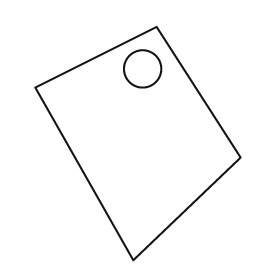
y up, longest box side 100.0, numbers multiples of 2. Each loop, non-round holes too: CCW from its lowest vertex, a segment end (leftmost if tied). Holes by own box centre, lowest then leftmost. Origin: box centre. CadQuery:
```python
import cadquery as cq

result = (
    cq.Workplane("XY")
    .moveTo(-2.0, -50.0)
    .lineTo(44.0, -6.0)
    .lineTo(8.0, 50.0)
    .lineTo(-44.0, 24.0)
    .close()
    .moveTo(2.0, 32.0)
    .circle(8.0)
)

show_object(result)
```